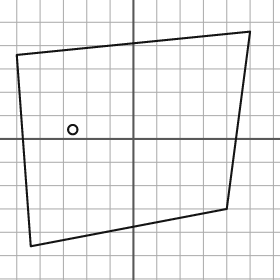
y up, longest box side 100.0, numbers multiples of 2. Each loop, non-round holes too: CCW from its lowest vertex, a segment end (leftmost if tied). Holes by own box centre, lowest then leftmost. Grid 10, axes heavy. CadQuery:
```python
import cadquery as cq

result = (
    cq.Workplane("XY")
    .moveTo(-44.0, -46.0)
    .lineTo(40.0, -30.0)
    .lineTo(50.0, 46.0)
    .lineTo(-50.0, 36.0)
    .close()
    .moveTo(-26.0, 4.0)
    .circle(2.0)
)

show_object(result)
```